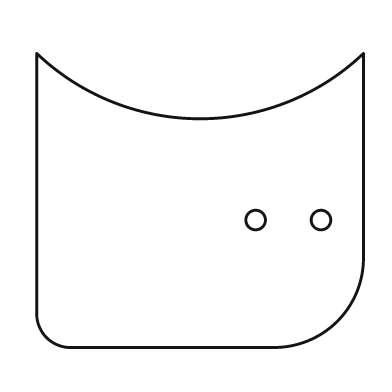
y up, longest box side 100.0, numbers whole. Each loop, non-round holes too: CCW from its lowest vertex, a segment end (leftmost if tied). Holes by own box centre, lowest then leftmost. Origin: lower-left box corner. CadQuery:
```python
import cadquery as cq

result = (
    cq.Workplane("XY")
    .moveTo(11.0, 0.0)
    .lineTo(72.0, 0.0)
    .threePointArc((92.0, 8.0), (100.0, 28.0))
    .lineTo(100.0, 90.0)
    .threePointArc((50.0, 70.0), (0.0, 90.0))
    .lineTo(0.0, 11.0)
    .threePointArc((3.0, 3.0), (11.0, 0.0))
    .close()
    .moveTo(67.0, 39.0)
    .circle(3.0)
    .moveTo(87.0, 39.0)
    .circle(3.0)
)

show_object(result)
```